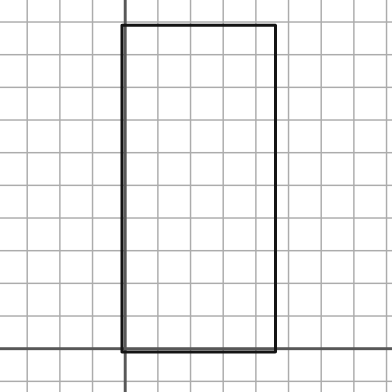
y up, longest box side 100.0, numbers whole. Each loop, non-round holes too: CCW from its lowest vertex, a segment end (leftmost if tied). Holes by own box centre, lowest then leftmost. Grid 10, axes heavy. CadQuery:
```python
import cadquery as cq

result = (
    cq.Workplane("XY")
    .moveTo(-1.0, -1.0)
    .lineTo(46.0, -1.0)
    .lineTo(46.0, 99.0)
    .lineTo(-1.0, 99.0)
    .close()
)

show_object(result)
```